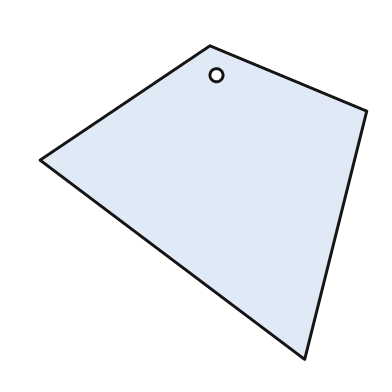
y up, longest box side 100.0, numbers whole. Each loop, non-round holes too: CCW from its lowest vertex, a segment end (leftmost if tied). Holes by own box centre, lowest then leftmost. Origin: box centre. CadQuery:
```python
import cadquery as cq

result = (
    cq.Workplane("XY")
    .moveTo(31.0, -48.0)
    .lineTo(50.0, 28.0)
    .lineTo(2.0, 48.0)
    .lineTo(-50.0, 13.0)
    .close()
    .moveTo(4.0, 39.0)
    .circle(2.0)
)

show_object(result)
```